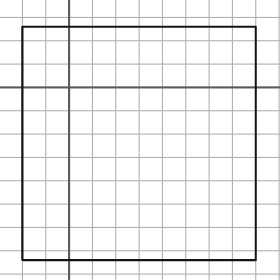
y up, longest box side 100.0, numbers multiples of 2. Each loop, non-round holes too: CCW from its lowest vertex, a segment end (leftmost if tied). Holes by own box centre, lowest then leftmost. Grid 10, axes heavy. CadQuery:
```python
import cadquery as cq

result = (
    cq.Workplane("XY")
    .moveTo(-20.0, -74.0)
    .lineTo(80.0, -74.0)
    .lineTo(80.0, 26.0)
    .lineTo(-20.0, 26.0)
    .close()
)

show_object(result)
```